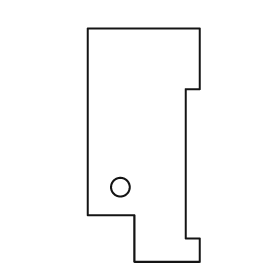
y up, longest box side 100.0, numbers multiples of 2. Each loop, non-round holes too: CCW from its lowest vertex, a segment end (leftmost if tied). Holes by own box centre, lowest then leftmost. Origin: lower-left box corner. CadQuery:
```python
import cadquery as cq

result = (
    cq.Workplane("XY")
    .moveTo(20.0, 0.0)
    .lineTo(48.0, 0.0)
    .lineTo(48.0, 10.0)
    .lineTo(42.0, 10.0)
    .lineTo(42.0, 74.0)
    .lineTo(48.0, 74.0)
    .lineTo(48.0, 100.0)
    .lineTo(0.0, 100.0)
    .lineTo(0.0, 20.0)
    .lineTo(20.0, 20.0)
    .close()
    .moveTo(14.0, 32.0)
    .circle(4.0)
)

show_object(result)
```